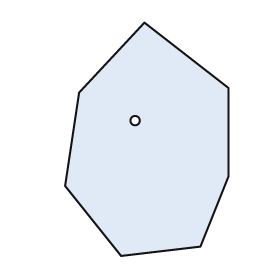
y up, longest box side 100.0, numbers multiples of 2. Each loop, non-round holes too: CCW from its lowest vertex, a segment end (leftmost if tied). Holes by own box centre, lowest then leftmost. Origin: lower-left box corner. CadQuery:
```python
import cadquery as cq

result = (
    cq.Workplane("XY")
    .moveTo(24.0, 0.0)
    .lineTo(58.0, 4.0)
    .lineTo(70.0, 34.0)
    .lineTo(70.0, 72.0)
    .lineTo(34.0, 100.0)
    .lineTo(6.0, 70.0)
    .lineTo(0.0, 30.0)
    .close()
    .moveTo(30.0, 58.0)
    .circle(2.0)
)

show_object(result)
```